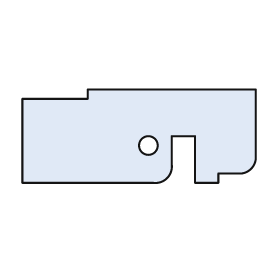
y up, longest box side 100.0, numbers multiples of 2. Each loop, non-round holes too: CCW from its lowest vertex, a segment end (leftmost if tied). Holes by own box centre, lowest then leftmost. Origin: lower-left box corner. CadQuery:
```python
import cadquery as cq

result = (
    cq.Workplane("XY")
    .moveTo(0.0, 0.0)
    .lineTo(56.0, 0.0)
    .threePointArc((62.0, 2.0), (64.0, 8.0))
    .lineTo(64.0, 20.0)
    .lineTo(74.0, 20.0)
    .lineTo(74.0, 0.0)
    .lineTo(84.0, 0.0)
    .lineTo(84.0, 4.0)
    .lineTo(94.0, 4.0)
    .threePointArc((98.0, 6.0), (100.0, 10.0))
    .lineTo(100.0, 40.0)
    .lineTo(28.0, 40.0)
    .lineTo(28.0, 36.0)
    .lineTo(0.0, 36.0)
    .close()
    .moveTo(54.0, 16.0)
    .circle(4.0)
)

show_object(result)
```